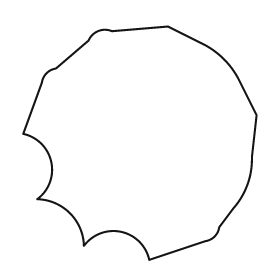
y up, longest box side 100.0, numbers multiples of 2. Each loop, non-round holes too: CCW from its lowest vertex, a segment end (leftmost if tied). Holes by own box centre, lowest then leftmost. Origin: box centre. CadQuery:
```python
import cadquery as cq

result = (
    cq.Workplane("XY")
    .moveTo(4.0, -50.0)
    .lineTo(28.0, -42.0)
    .threePointArc((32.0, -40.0), (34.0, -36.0))
    .lineTo(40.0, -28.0)
    .threePointArc((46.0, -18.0), (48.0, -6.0))
    .lineTo(50.0, 12.0)
    .lineTo(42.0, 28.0)
    .threePointArc((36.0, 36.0), (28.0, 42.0))
    .lineTo(12.0, 50.0)
    .lineTo(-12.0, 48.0)
    .threePointArc((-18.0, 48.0), (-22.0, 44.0))
    .lineTo(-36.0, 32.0)
    .threePointArc((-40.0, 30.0), (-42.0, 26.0))
    .lineTo(-50.0, 4.0)
    .threePointArc((-38.0, -8.0), (-44.0, -24.0))
    .threePointArc((-30.0, -30.0), (-24.0, -44.0))
    .threePointArc((-8.0, -38.0), (4.0, -50.0))
    .close()
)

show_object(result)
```